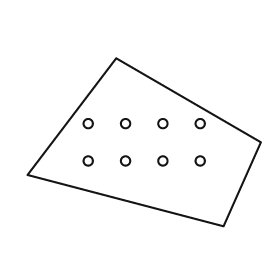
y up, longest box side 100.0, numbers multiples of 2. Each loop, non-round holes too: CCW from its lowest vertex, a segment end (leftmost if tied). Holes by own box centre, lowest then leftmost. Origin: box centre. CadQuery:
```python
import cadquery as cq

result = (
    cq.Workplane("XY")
    .moveTo(34.0, -36.0)
    .lineTo(50.0, 0.0)
    .lineTo(-12.0, 36.0)
    .lineTo(-50.0, -14.0)
    .close()
    .moveTo(-24.0, -8.0)
    .circle(2.0)
    .moveTo(-8.0, -8.0)
    .circle(2.0)
    .moveTo(8.0, -8.0)
    .circle(2.0)
    .moveTo(24.0, -8.0)
    .circle(2.0)
    .moveTo(-24.0, 8.0)
    .circle(2.0)
    .moveTo(-8.0, 8.0)
    .circle(2.0)
    .moveTo(8.0, 8.0)
    .circle(2.0)
    .moveTo(24.0, 8.0)
    .circle(2.0)
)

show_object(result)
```